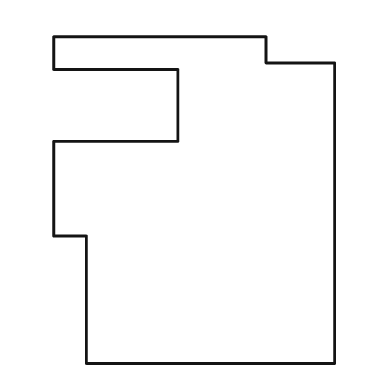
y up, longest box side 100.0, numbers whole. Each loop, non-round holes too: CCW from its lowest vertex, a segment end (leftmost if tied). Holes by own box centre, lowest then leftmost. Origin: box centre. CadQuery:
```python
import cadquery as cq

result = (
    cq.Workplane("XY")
    .moveTo(-33.0, -50.0)
    .lineTo(43.0, -50.0)
    .lineTo(43.0, 42.0)
    .lineTo(22.0, 42.0)
    .lineTo(22.0, 50.0)
    .lineTo(-43.0, 50.0)
    .lineTo(-43.0, 40.0)
    .lineTo(-5.0, 40.0)
    .lineTo(-5.0, 18.0)
    .lineTo(-43.0, 18.0)
    .lineTo(-43.0, -11.0)
    .lineTo(-33.0, -11.0)
    .close()
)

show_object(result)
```